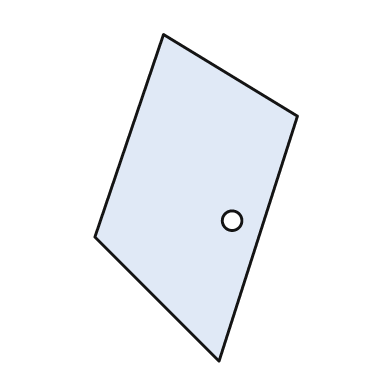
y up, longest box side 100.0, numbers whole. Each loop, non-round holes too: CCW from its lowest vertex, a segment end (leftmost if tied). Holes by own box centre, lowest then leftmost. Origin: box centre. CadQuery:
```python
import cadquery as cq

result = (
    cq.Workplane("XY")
    .moveTo(7.0, -50.0)
    .lineTo(31.0, 25.0)
    .lineTo(-10.0, 50.0)
    .lineTo(-31.0, -12.0)
    .close()
    .moveTo(11.0, -7.0)
    .circle(3.0)
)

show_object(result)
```